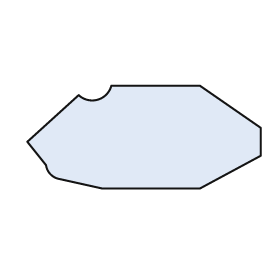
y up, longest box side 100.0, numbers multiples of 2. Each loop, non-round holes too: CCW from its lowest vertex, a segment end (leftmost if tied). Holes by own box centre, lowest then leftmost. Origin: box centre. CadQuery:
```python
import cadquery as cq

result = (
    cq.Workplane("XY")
    .moveTo(-18.0, -22.0)
    .lineTo(24.0, -22.0)
    .lineTo(50.0, -8.0)
    .lineTo(50.0, 4.0)
    .lineTo(24.0, 22.0)
    .lineTo(-14.0, 22.0)
    .threePointArc((-20.0, 16.0), (-28.0, 18.0))
    .lineTo(-50.0, -2.0)
    .lineTo(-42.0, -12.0)
    .threePointArc((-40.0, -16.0), (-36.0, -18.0))
    .close()
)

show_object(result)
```